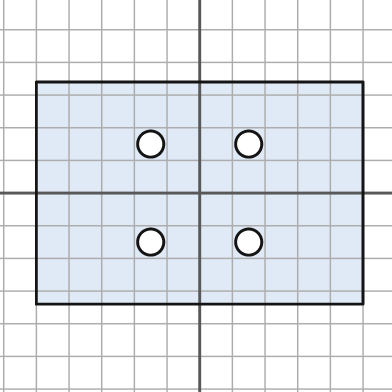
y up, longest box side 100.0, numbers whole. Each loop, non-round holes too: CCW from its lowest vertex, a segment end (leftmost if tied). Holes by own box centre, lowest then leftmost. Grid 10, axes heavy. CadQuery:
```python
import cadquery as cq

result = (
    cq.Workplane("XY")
    .moveTo(-50.0, -34.0)
    .lineTo(50.0, -34.0)
    .lineTo(50.0, 34.0)
    .lineTo(-50.0, 34.0)
    .close()
    .moveTo(-15.0, -15.0)
    .circle(4.0)
    .moveTo(15.0, -15.0)
    .circle(4.0)
    .moveTo(-15.0, 15.0)
    .circle(4.0)
    .moveTo(15.0, 15.0)
    .circle(4.0)
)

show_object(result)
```